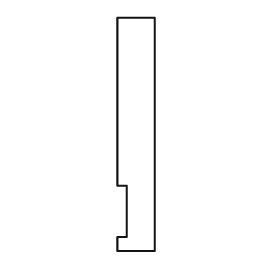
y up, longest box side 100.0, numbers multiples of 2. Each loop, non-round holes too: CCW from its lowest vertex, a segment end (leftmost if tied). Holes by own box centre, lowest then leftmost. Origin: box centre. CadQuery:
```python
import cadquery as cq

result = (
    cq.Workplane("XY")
    .moveTo(-8.0, -50.0)
    .lineTo(8.0, -50.0)
    .lineTo(8.0, 50.0)
    .lineTo(-8.0, 50.0)
    .lineTo(-8.0, -22.0)
    .lineTo(-4.0, -22.0)
    .lineTo(-4.0, -44.0)
    .lineTo(-8.0, -44.0)
    .close()
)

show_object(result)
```